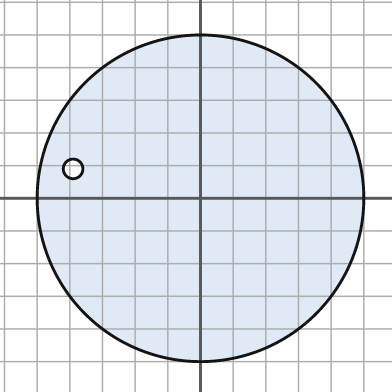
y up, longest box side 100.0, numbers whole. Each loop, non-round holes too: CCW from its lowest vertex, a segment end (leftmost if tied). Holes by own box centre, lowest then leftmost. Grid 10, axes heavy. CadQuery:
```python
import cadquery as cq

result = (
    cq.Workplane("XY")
    .moveTo(0.0, 0.0)
    .circle(50.0)
    .moveTo(-39.0, 9.0)
    .circle(3.0)
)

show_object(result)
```